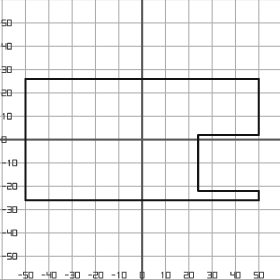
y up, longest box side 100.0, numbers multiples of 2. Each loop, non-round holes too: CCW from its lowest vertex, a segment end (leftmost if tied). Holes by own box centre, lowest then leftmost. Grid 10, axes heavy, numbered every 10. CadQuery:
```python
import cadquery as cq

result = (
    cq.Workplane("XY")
    .moveTo(-50.0, -26.0)
    .lineTo(50.0, -26.0)
    .lineTo(50.0, -22.0)
    .lineTo(24.0, -22.0)
    .lineTo(24.0, 2.0)
    .lineTo(50.0, 2.0)
    .lineTo(50.0, 26.0)
    .lineTo(-50.0, 26.0)
    .close()
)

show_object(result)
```